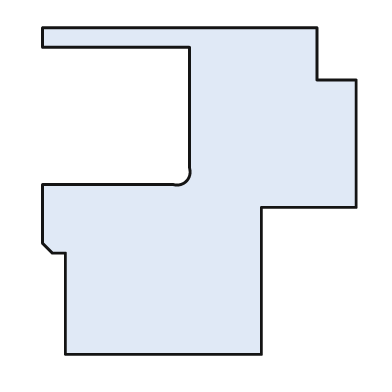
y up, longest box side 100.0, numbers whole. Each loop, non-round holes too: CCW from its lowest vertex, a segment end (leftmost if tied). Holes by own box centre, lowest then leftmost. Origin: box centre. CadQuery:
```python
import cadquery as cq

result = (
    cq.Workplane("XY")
    .moveTo(-41.0, -50.0)
    .lineTo(19.0, -50.0)
    .lineTo(19.0, -5.0)
    .lineTo(48.0, -5.0)
    .lineTo(48.0, 34.0)
    .lineTo(36.0, 34.0)
    .lineTo(36.0, 50.0)
    .lineTo(-48.0, 50.0)
    .lineTo(-48.0, 44.0)
    .lineTo(-3.0, 44.0)
    .lineTo(-3.0, 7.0)
    .threePointArc((-4.0, 3.0), (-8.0, 2.0))
    .lineTo(-48.0, 2.0)
    .lineTo(-48.0, -16.0)
    .lineTo(-45.0, -19.0)
    .lineTo(-41.0, -19.0)
    .close()
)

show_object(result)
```